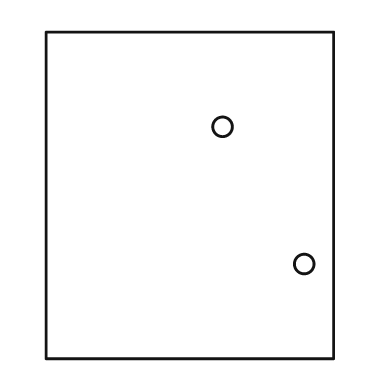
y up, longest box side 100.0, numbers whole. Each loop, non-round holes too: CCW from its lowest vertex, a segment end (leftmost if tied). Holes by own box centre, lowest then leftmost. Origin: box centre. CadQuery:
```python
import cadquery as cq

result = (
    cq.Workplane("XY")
    .moveTo(-44.0, -50.0)
    .lineTo(44.0, -50.0)
    .lineTo(44.0, 50.0)
    .lineTo(-44.0, 50.0)
    .close()
    .moveTo(35.0, -21.0)
    .circle(3.0)
    .moveTo(10.0, 21.0)
    .circle(3.0)
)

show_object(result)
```